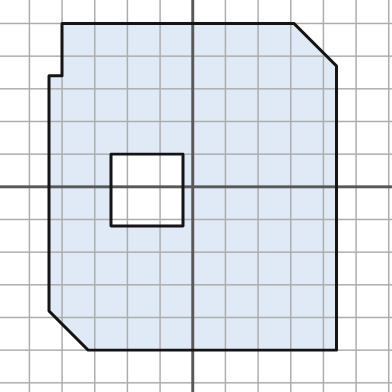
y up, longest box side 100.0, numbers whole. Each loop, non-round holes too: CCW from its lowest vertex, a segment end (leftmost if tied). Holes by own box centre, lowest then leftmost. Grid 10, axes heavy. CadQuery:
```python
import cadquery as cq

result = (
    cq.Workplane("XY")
    .moveTo(-32.0, -50.0)
    .lineTo(44.0, -50.0)
    .lineTo(44.0, 37.0)
    .lineTo(31.0, 50.0)
    .lineTo(-40.0, 50.0)
    .lineTo(-40.0, 34.0)
    .lineTo(-44.0, 34.0)
    .lineTo(-44.0, -38.0)
    .close()
    .moveTo(-25.0, -12.0)
    .lineTo(-3.0, -12.0)
    .lineTo(-3.0, 10.0)
    .lineTo(-25.0, 10.0)
    .close()
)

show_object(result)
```